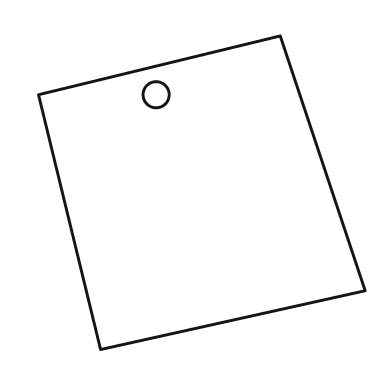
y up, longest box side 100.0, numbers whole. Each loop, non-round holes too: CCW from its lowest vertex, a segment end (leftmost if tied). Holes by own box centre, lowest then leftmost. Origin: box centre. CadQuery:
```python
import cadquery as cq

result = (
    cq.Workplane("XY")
    .moveTo(-31.0, -48.0)
    .lineTo(50.0, -30.0)
    .lineTo(24.0, 48.0)
    .lineTo(-50.0, 30.0)
    .close()
    .moveTo(-14.0, 30.0)
    .circle(4.0)
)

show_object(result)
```